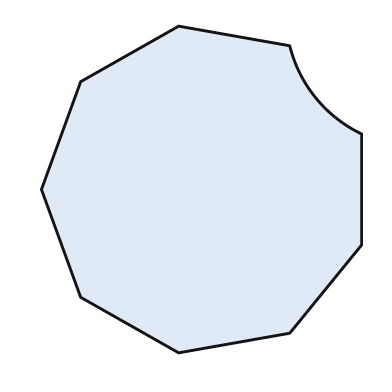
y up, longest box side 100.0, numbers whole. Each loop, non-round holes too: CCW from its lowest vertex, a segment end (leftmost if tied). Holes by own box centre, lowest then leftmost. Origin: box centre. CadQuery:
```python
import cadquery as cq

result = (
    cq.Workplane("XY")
    .moveTo(-7.0, -50.0)
    .lineTo(27.0, -44.0)
    .lineTo(49.0, -17.0)
    .lineTo(49.0, 17.0)
    .threePointArc((35.0, 28.0), (27.0, 44.0))
    .lineTo(-7.0, 50.0)
    .lineTo(-37.0, 33.0)
    .lineTo(-49.0, 0.0)
    .lineTo(-37.0, -33.0)
    .close()
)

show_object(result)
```